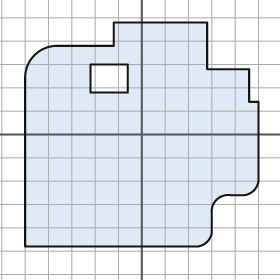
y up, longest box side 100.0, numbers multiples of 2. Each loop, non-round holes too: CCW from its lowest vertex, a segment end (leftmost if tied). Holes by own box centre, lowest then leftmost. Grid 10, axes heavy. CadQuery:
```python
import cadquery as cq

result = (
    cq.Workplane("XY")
    .moveTo(-50.0, -48.0)
    .lineTo(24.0, -48.0)
    .threePointArc((28.0, -46.0), (30.0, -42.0))
    .lineTo(30.0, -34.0)
    .threePointArc((32.0, -28.0), (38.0, -26.0))
    .lineTo(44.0, -26.0)
    .threePointArc((48.0, -24.0), (50.0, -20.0))
    .lineTo(50.0, 14.0)
    .lineTo(46.0, 14.0)
    .lineTo(46.0, 28.0)
    .lineTo(28.0, 28.0)
    .lineTo(28.0, 48.0)
    .lineTo(-12.0, 48.0)
    .lineTo(-12.0, 38.0)
    .lineTo(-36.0, 38.0)
    .threePointArc((-46.0, 34.0), (-50.0, 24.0))
    .close()
    .moveTo(-22.0, 18.0)
    .lineTo(-6.0, 18.0)
    .lineTo(-6.0, 30.0)
    .lineTo(-22.0, 30.0)
    .close()
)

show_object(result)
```